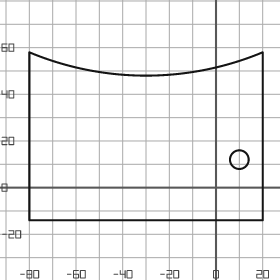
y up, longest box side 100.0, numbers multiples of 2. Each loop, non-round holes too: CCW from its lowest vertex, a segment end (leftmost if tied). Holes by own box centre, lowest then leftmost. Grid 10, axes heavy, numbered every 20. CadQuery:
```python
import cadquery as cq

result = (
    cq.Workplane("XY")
    .moveTo(-80.0, -14.0)
    .lineTo(20.0, -14.0)
    .lineTo(20.0, 58.0)
    .threePointArc((-30.0, 48.0), (-80.0, 58.0))
    .close()
    .moveTo(10.0, 12.0)
    .circle(4.0)
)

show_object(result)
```